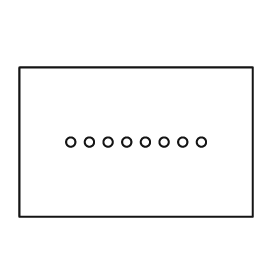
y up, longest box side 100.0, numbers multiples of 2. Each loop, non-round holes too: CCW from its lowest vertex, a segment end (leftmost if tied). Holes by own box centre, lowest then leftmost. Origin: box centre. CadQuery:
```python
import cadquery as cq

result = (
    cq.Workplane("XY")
    .moveTo(-50.0, -32.0)
    .lineTo(50.0, -32.0)
    .lineTo(50.0, 32.0)
    .lineTo(-50.0, 32.0)
    .close()
    .moveTo(-28.0, 0.0)
    .circle(2.0)
    .moveTo(-20.0, 0.0)
    .circle(2.0)
    .moveTo(-12.0, 0.0)
    .circle(2.0)
    .moveTo(-4.0, 0.0)
    .circle(2.0)
    .moveTo(4.0, 0.0)
    .circle(2.0)
    .moveTo(12.0, 0.0)
    .circle(2.0)
    .moveTo(20.0, 0.0)
    .circle(2.0)
    .moveTo(28.0, 0.0)
    .circle(2.0)
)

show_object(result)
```